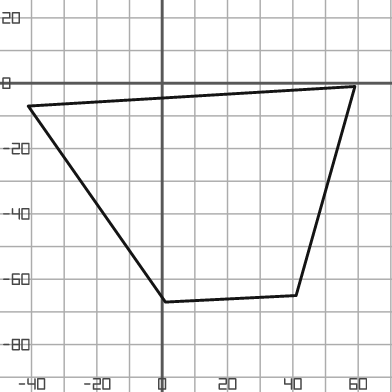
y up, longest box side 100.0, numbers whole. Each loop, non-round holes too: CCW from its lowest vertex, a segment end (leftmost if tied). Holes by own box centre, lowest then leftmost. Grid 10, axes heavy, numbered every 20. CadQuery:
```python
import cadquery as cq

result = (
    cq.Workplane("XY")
    .moveTo(1.0, -67.0)
    .lineTo(41.0, -65.0)
    .lineTo(59.0, -1.0)
    .lineTo(-41.0, -7.0)
    .close()
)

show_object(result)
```